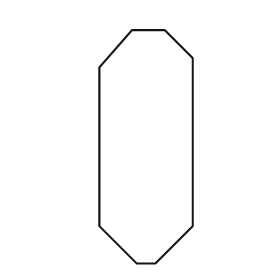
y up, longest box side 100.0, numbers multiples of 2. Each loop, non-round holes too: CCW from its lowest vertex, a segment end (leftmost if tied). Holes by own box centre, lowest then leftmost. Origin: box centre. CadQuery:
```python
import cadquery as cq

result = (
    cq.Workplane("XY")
    .moveTo(-4.0, -50.0)
    .lineTo(4.0, -50.0)
    .lineTo(20.0, -34.0)
    .lineTo(20.0, 38.0)
    .lineTo(8.0, 50.0)
    .lineTo(-6.0, 50.0)
    .lineTo(-20.0, 34.0)
    .lineTo(-20.0, -34.0)
    .close()
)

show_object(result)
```